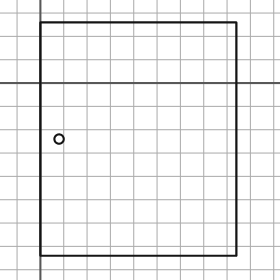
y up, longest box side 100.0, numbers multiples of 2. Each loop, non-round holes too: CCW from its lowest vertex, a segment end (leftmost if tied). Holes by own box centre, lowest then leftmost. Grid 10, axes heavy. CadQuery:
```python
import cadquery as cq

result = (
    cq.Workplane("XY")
    .moveTo(0.0, -74.0)
    .lineTo(84.0, -74.0)
    .lineTo(84.0, 26.0)
    .lineTo(0.0, 26.0)
    .close()
    .moveTo(8.0, -24.0)
    .circle(2.0)
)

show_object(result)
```